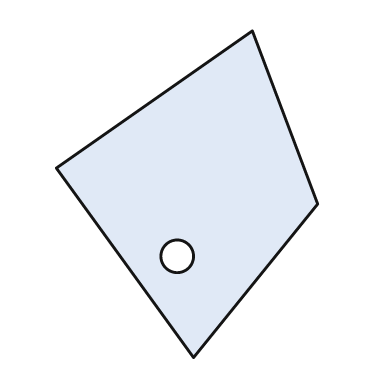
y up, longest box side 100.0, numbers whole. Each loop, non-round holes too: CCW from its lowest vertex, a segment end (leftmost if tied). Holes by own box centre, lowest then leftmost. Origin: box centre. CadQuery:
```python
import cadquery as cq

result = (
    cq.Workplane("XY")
    .moveTo(2.0, -50.0)
    .lineTo(40.0, -3.0)
    .lineTo(20.0, 50.0)
    .lineTo(-40.0, 8.0)
    .close()
    .moveTo(-3.0, -19.0)
    .circle(5.0)
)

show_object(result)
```